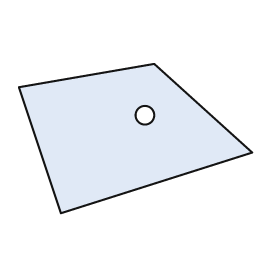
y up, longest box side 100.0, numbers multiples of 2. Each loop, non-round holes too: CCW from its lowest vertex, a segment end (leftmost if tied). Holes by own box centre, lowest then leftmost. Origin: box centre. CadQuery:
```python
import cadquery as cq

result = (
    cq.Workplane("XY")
    .moveTo(-32.0, -32.0)
    .lineTo(50.0, -6.0)
    .lineTo(8.0, 32.0)
    .lineTo(-50.0, 22.0)
    .close()
    .moveTo(4.0, 10.0)
    .circle(4.0)
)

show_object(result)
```